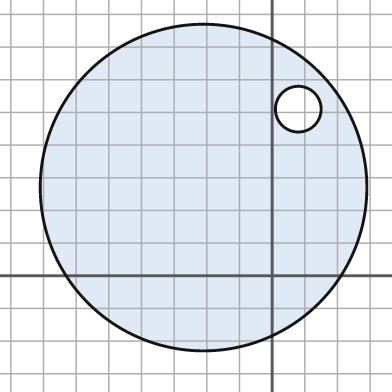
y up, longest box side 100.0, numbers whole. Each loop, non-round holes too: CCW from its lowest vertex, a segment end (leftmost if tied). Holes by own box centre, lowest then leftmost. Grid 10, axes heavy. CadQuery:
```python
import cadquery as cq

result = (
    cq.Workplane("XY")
    .moveTo(-21.0, 27.0)
    .circle(50.0)
    .moveTo(8.0, 51.0)
    .circle(7.0)
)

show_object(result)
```